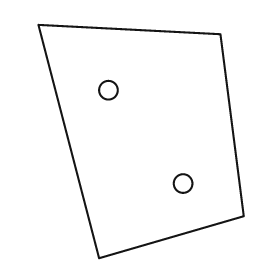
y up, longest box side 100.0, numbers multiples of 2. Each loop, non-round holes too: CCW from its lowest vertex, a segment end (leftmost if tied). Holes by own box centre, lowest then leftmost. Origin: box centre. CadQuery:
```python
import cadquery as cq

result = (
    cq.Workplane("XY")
    .moveTo(-18.0, -50.0)
    .lineTo(44.0, -32.0)
    .lineTo(34.0, 46.0)
    .lineTo(-44.0, 50.0)
    .close()
    .moveTo(18.0, -18.0)
    .circle(4.0)
    .moveTo(-14.0, 22.0)
    .circle(4.0)
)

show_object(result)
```